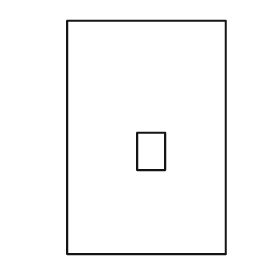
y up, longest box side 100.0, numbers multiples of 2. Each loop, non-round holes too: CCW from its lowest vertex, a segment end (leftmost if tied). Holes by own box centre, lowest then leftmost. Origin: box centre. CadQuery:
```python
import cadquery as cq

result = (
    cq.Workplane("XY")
    .moveTo(-34.0, -50.0)
    .lineTo(34.0, -50.0)
    .lineTo(34.0, 50.0)
    .lineTo(-34.0, 50.0)
    .close()
    .moveTo(-4.0, -14.0)
    .lineTo(8.0, -14.0)
    .lineTo(8.0, 2.0)
    .lineTo(-4.0, 2.0)
    .close()
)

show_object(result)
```